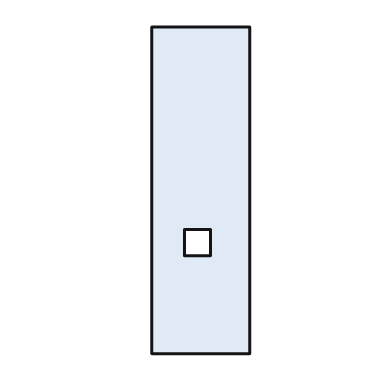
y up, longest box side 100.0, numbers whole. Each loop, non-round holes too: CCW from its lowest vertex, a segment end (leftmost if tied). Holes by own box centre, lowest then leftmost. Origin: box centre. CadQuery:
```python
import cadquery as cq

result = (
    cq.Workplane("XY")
    .moveTo(-15.0, -50.0)
    .lineTo(15.0, -50.0)
    .lineTo(15.0, 50.0)
    .lineTo(-15.0, 50.0)
    .close()
    .moveTo(-5.0, -20.0)
    .lineTo(3.0, -20.0)
    .lineTo(3.0, -12.0)
    .lineTo(-5.0, -12.0)
    .close()
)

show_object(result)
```